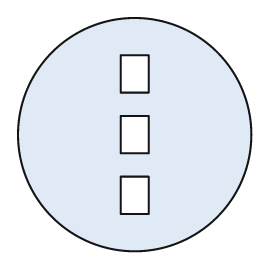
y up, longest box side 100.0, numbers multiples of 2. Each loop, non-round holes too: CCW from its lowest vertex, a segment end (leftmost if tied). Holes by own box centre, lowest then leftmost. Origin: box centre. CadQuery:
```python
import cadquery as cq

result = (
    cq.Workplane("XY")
    .moveTo(0.0, 0.0)
    .circle(50.0)
    .moveTo(-6.0, -34.0)
    .lineTo(6.0, -34.0)
    .lineTo(6.0, -18.0)
    .lineTo(-6.0, -18.0)
    .close()
    .moveTo(-6.0, -8.0)
    .lineTo(6.0, -8.0)
    .lineTo(6.0, 8.0)
    .lineTo(-6.0, 8.0)
    .close()
    .moveTo(-6.0, 18.0)
    .lineTo(6.0, 18.0)
    .lineTo(6.0, 34.0)
    .lineTo(-6.0, 34.0)
    .close()
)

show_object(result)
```